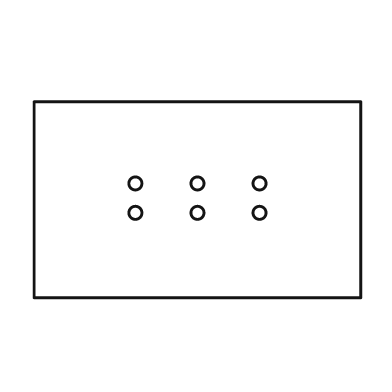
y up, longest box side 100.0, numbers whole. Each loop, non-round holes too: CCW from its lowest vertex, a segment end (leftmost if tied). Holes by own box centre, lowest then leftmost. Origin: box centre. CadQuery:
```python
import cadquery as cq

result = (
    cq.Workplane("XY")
    .moveTo(-50.0, -30.0)
    .lineTo(50.0, -30.0)
    .lineTo(50.0, 30.0)
    .lineTo(-50.0, 30.0)
    .close()
    .moveTo(-19.0, -4.0)
    .circle(2.0)
    .moveTo(0.0, -4.0)
    .circle(2.0)
    .moveTo(19.0, -4.0)
    .circle(2.0)
    .moveTo(-19.0, 5.0)
    .circle(2.0)
    .moveTo(0.0, 5.0)
    .circle(2.0)
    .moveTo(19.0, 5.0)
    .circle(2.0)
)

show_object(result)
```